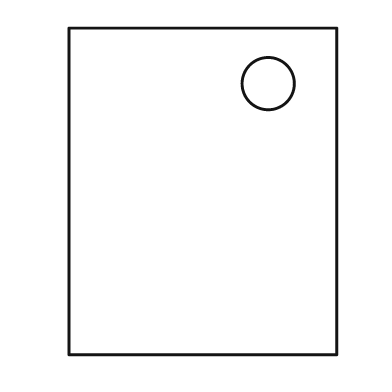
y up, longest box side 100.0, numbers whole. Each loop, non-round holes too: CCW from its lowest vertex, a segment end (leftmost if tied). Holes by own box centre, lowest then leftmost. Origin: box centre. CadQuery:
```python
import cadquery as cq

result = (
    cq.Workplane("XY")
    .moveTo(-41.0, -50.0)
    .lineTo(41.0, -50.0)
    .lineTo(41.0, 50.0)
    .lineTo(-41.0, 50.0)
    .close()
    .moveTo(20.0, 33.0)
    .circle(8.0)
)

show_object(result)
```